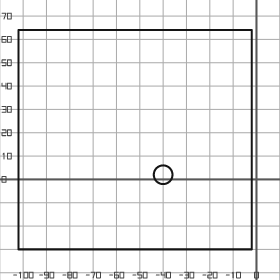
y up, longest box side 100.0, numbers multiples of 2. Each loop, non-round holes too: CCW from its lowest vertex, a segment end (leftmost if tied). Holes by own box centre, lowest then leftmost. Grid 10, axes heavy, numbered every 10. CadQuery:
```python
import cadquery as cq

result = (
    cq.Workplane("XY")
    .moveTo(-102.0, -30.0)
    .lineTo(-2.0, -30.0)
    .lineTo(-2.0, 64.0)
    .lineTo(-102.0, 64.0)
    .close()
    .moveTo(-40.0, 2.0)
    .circle(4.0)
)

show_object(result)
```